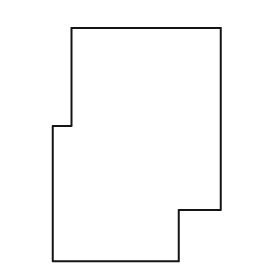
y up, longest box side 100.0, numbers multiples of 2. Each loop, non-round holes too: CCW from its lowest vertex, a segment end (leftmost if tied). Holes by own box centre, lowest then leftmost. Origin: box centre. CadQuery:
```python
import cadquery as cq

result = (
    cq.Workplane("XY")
    .moveTo(-36.0, -50.0)
    .lineTo(18.0, -50.0)
    .lineTo(18.0, -28.0)
    .lineTo(36.0, -28.0)
    .lineTo(36.0, 50.0)
    .lineTo(-28.0, 50.0)
    .lineTo(-28.0, 8.0)
    .lineTo(-36.0, 8.0)
    .close()
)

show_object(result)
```